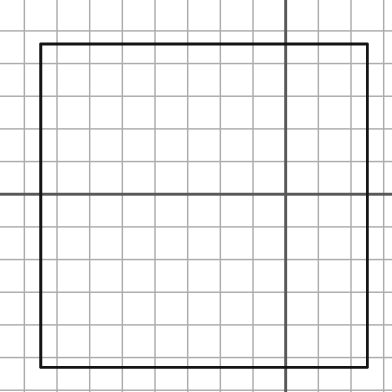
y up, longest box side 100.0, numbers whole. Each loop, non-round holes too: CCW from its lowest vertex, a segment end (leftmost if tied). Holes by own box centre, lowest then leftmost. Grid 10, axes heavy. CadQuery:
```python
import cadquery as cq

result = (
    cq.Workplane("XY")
    .moveTo(-75.0, -53.0)
    .lineTo(25.0, -53.0)
    .lineTo(25.0, 46.0)
    .lineTo(-75.0, 46.0)
    .close()
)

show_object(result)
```